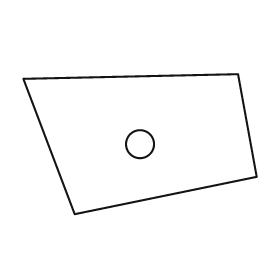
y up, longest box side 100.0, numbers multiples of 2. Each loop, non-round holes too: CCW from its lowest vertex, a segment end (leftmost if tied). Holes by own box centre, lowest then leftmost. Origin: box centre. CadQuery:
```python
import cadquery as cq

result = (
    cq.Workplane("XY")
    .moveTo(-28.0, -30.0)
    .lineTo(50.0, -14.0)
    .lineTo(42.0, 30.0)
    .lineTo(-50.0, 28.0)
    .close()
    .moveTo(0.0, 0.0)
    .circle(6.0)
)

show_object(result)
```